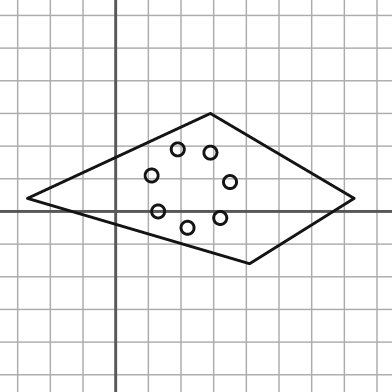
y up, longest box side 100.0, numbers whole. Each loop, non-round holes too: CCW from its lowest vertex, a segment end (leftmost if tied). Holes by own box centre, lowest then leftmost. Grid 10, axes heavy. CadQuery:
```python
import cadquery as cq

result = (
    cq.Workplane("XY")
    .moveTo(41.0, -16.0)
    .lineTo(73.0, 4.0)
    .lineTo(29.0, 30.0)
    .lineTo(-27.0, 4.0)
    .close()
    .moveTo(22.0, -5.0)
    .circle(2.0)
    .moveTo(32.0, -2.0)
    .circle(2.0)
    .moveTo(13.0, 0.0)
    .circle(2.0)
    .moveTo(35.0, 9.0)
    .circle(2.0)
    .moveTo(11.0, 11.0)
    .circle(2.0)
    .moveTo(29.0, 18.0)
    .circle(2.0)
    .moveTo(19.0, 19.0)
    .circle(2.0)
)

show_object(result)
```